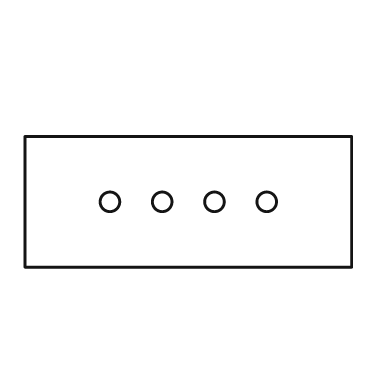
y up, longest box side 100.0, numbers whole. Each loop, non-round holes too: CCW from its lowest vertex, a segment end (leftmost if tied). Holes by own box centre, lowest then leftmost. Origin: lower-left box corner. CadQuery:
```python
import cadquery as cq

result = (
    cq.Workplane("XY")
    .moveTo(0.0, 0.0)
    .lineTo(100.0, 0.0)
    .lineTo(100.0, 40.0)
    .lineTo(0.0, 40.0)
    .close()
    .moveTo(26.0, 20.0)
    .circle(3.0)
    .moveTo(42.0, 20.0)
    .circle(3.0)
    .moveTo(58.0, 20.0)
    .circle(3.0)
    .moveTo(74.0, 20.0)
    .circle(3.0)
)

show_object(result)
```